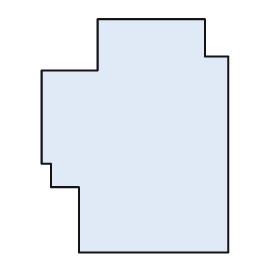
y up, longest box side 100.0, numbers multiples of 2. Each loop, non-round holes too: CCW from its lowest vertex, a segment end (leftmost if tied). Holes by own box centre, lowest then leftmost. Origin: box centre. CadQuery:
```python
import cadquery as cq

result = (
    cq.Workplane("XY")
    .moveTo(-24.0, -50.0)
    .lineTo(40.0, -50.0)
    .lineTo(40.0, 34.0)
    .lineTo(30.0, 34.0)
    .lineTo(30.0, 50.0)
    .lineTo(-16.0, 50.0)
    .lineTo(-16.0, 28.0)
    .lineTo(-40.0, 28.0)
    .lineTo(-40.0, -12.0)
    .lineTo(-36.0, -12.0)
    .lineTo(-36.0, -22.0)
    .lineTo(-24.0, -22.0)
    .close()
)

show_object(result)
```